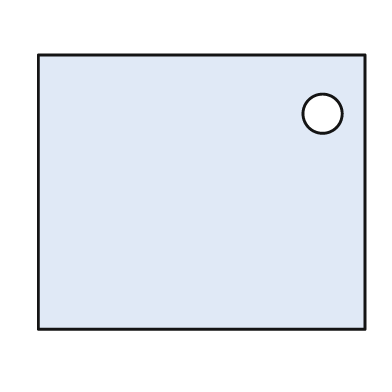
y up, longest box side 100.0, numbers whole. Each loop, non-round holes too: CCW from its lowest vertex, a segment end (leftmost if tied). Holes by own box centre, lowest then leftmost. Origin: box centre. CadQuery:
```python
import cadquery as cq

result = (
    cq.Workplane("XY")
    .moveTo(-50.0, -42.0)
    .lineTo(50.0, -42.0)
    .lineTo(50.0, 42.0)
    .lineTo(-50.0, 42.0)
    .close()
    .moveTo(37.0, 24.0)
    .circle(6.0)
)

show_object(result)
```